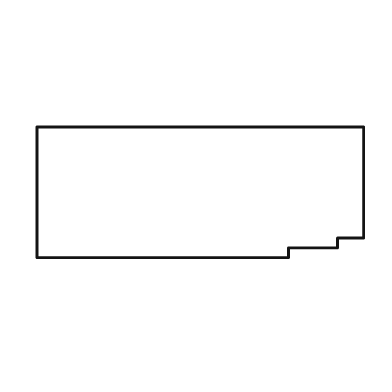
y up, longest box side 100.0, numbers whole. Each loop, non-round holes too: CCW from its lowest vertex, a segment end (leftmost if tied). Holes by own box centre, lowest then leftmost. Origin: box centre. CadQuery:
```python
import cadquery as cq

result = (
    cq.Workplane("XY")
    .moveTo(-50.0, -20.0)
    .lineTo(27.0, -20.0)
    .lineTo(27.0, -17.0)
    .lineTo(42.0, -17.0)
    .lineTo(42.0, -14.0)
    .lineTo(50.0, -14.0)
    .lineTo(50.0, 20.0)
    .lineTo(-50.0, 20.0)
    .close()
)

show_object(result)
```